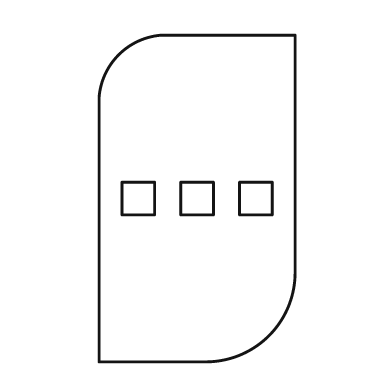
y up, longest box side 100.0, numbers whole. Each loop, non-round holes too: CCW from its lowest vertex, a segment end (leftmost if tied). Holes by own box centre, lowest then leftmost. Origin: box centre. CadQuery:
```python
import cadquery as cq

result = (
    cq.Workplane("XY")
    .moveTo(-30.0, -50.0)
    .lineTo(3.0, -50.0)
    .threePointArc((22.0, -42.0), (30.0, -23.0))
    .lineTo(30.0, 50.0)
    .lineTo(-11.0, 50.0)
    .threePointArc((-24.0, 44.0), (-30.0, 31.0))
    .close()
    .moveTo(-23.0, -5.0)
    .lineTo(-13.0, -5.0)
    .lineTo(-13.0, 5.0)
    .lineTo(-23.0, 5.0)
    .close()
    .moveTo(-5.0, -5.0)
    .lineTo(5.0, -5.0)
    .lineTo(5.0, 5.0)
    .lineTo(-5.0, 5.0)
    .close()
    .moveTo(13.0, -5.0)
    .lineTo(23.0, -5.0)
    .lineTo(23.0, 5.0)
    .lineTo(13.0, 5.0)
    .close()
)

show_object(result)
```